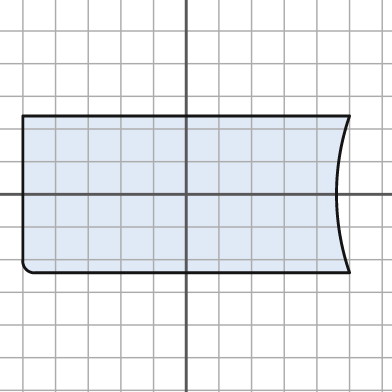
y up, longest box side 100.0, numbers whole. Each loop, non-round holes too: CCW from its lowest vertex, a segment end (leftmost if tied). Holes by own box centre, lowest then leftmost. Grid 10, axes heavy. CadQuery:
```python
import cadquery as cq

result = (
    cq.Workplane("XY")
    .moveTo(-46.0, -24.0)
    .lineTo(50.0, -24.0)
    .threePointArc((46.0, 0.0), (50.0, 24.0))
    .lineTo(-50.0, 24.0)
    .lineTo(-50.0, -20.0)
    .threePointArc((-49.0, -23.0), (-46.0, -24.0))
    .close()
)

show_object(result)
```